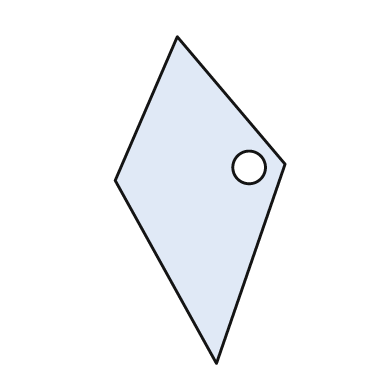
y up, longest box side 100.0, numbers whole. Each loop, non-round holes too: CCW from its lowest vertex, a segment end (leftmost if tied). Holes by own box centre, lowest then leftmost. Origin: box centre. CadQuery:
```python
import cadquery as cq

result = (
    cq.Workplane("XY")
    .moveTo(5.0, -50.0)
    .lineTo(26.0, 11.0)
    .lineTo(-7.0, 50.0)
    .lineTo(-26.0, 6.0)
    .close()
    .moveTo(15.0, 10.0)
    .circle(5.0)
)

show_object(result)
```